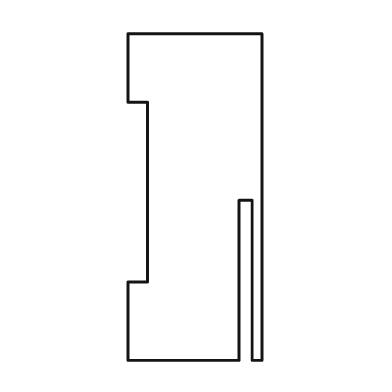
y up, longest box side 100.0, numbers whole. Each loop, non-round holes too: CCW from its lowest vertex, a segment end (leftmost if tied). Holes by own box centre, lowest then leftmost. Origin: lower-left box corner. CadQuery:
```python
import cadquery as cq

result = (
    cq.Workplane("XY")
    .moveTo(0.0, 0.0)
    .lineTo(34.0, 0.0)
    .lineTo(34.0, 49.0)
    .lineTo(38.0, 49.0)
    .lineTo(38.0, 0.0)
    .lineTo(41.0, 0.0)
    .lineTo(41.0, 100.0)
    .lineTo(0.0, 100.0)
    .lineTo(0.0, 79.0)
    .lineTo(6.0, 79.0)
    .lineTo(6.0, 24.0)
    .lineTo(0.0, 24.0)
    .close()
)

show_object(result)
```